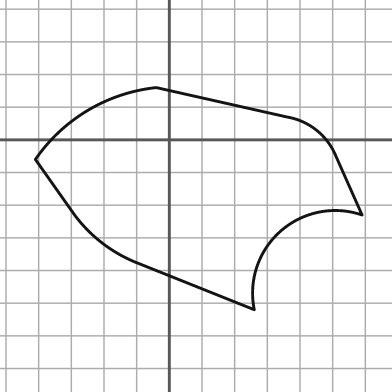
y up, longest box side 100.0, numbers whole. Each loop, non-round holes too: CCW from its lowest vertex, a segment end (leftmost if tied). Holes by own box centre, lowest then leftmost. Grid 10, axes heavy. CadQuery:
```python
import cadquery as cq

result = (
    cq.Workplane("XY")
    .moveTo(26.0, -52.0)
    .threePointArc((34.0, -28.0), (59.0, -23.0))
    .lineTo(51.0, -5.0)
    .threePointArc((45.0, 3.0), (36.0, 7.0))
    .lineTo(-4.0, 16.0)
    .threePointArc((-25.0, 9.0), (-41.0, -6.0))
    .lineTo(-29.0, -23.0)
    .threePointArc((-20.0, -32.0), (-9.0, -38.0))
    .close()
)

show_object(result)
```